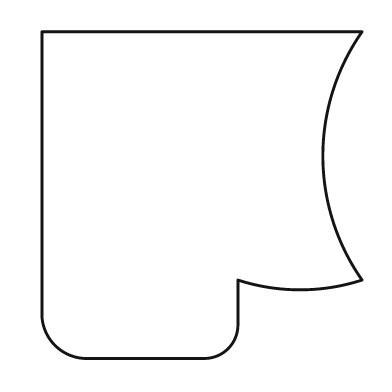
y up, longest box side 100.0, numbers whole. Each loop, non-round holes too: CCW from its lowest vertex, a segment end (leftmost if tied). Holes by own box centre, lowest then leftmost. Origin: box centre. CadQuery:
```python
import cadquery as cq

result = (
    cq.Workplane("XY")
    .moveTo(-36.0, -50.0)
    .lineTo(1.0, -50.0)
    .threePointArc((8.0, -47.0), (11.0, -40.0))
    .lineTo(11.0, -26.0)
    .threePointArc((30.0, -29.0), (49.0, -26.0))
    .threePointArc((37.0, 12.0), (49.0, 50.0))
    .lineTo(-49.0, 50.0)
    .lineTo(-49.0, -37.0)
    .threePointArc((-45.0, -46.0), (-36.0, -50.0))
    .close()
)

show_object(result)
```